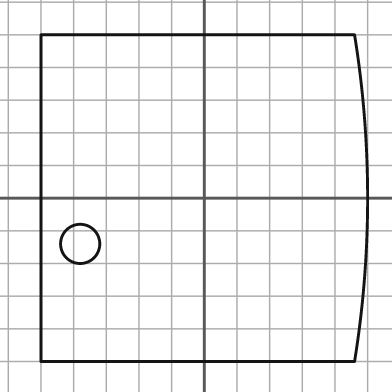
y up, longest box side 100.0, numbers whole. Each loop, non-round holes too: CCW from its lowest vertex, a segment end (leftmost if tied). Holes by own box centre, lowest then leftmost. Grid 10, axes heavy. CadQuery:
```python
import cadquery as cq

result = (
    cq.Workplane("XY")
    .moveTo(-50.0, -50.0)
    .lineTo(46.0, -50.0)
    .threePointArc((50.0, 0.0), (46.0, 50.0))
    .lineTo(-50.0, 50.0)
    .close()
    .moveTo(-38.0, -14.0)
    .circle(6.0)
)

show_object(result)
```